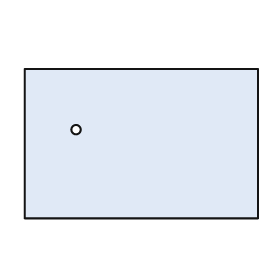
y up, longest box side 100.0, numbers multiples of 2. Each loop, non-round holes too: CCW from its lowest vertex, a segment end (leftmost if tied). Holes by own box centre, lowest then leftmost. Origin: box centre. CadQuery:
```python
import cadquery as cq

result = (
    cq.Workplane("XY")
    .moveTo(-50.0, -32.0)
    .lineTo(50.0, -32.0)
    .lineTo(50.0, 32.0)
    .lineTo(-50.0, 32.0)
    .close()
    .moveTo(-28.0, 6.0)
    .circle(2.0)
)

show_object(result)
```